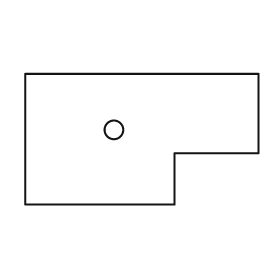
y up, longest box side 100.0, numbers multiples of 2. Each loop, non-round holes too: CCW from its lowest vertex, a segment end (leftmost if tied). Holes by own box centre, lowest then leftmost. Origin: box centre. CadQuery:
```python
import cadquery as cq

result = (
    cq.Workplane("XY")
    .moveTo(-50.0, -28.0)
    .lineTo(14.0, -28.0)
    .lineTo(14.0, -6.0)
    .lineTo(50.0, -6.0)
    .lineTo(50.0, 28.0)
    .lineTo(-50.0, 28.0)
    .close()
    .moveTo(-12.0, 4.0)
    .circle(4.0)
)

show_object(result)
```